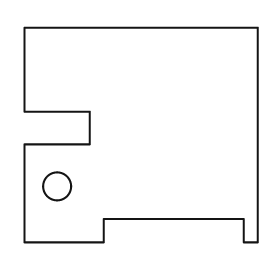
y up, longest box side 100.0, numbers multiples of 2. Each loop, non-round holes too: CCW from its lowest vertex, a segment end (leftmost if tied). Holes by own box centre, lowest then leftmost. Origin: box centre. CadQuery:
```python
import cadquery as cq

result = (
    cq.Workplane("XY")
    .moveTo(-50.0, -46.0)
    .lineTo(-16.0, -46.0)
    .lineTo(-16.0, -36.0)
    .lineTo(44.0, -36.0)
    .lineTo(44.0, -46.0)
    .lineTo(50.0, -46.0)
    .lineTo(50.0, 46.0)
    .lineTo(-50.0, 46.0)
    .lineTo(-50.0, 10.0)
    .lineTo(-22.0, 10.0)
    .lineTo(-22.0, -4.0)
    .lineTo(-50.0, -4.0)
    .close()
    .moveTo(-36.0, -22.0)
    .circle(6.0)
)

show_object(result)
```